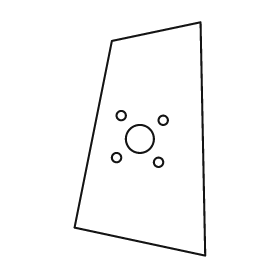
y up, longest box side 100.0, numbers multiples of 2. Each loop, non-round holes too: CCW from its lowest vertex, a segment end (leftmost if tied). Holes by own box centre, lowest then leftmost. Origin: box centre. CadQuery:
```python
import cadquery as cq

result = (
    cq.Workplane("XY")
    .moveTo(28.0, -50.0)
    .lineTo(26.0, 50.0)
    .lineTo(-12.0, 42.0)
    .lineTo(-28.0, -38.0)
    .close()
    .moveTo(8.0, -10.0)
    .circle(2.0)
    .moveTo(-10.0, -8.0)
    .circle(2.0)
    .moveTo(0.0, 0.0)
    .circle(6.0)
    .moveTo(10.0, 8.0)
    .circle(2.0)
    .moveTo(-8.0, 10.0)
    .circle(2.0)
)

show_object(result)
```